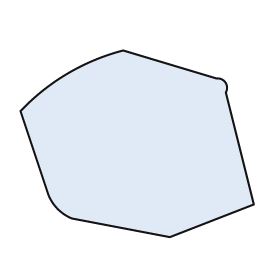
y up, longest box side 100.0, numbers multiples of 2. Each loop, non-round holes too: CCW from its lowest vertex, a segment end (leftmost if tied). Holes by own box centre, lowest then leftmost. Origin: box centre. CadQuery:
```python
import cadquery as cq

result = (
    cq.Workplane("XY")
    .moveTo(14.0, -40.0)
    .lineTo(50.0, -26.0)
    .lineTo(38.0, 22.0)
    .threePointArc((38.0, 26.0), (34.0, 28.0))
    .lineTo(-6.0, 40.0)
    .threePointArc((-30.0, 30.0), (-50.0, 14.0))
    .lineTo(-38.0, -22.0)
    .threePointArc((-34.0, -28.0), (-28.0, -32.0))
    .close()
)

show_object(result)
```